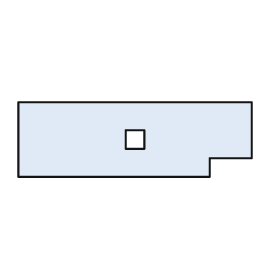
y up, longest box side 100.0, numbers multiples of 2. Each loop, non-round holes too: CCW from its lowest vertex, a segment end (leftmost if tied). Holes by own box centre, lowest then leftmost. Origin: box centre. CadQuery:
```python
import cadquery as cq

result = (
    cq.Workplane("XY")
    .moveTo(-50.0, -16.0)
    .lineTo(32.0, -16.0)
    .lineTo(32.0, -8.0)
    .lineTo(50.0, -8.0)
    .lineTo(50.0, 16.0)
    .lineTo(-50.0, 16.0)
    .close()
    .moveTo(-4.0, -4.0)
    .lineTo(4.0, -4.0)
    .lineTo(4.0, 4.0)
    .lineTo(-4.0, 4.0)
    .close()
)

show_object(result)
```